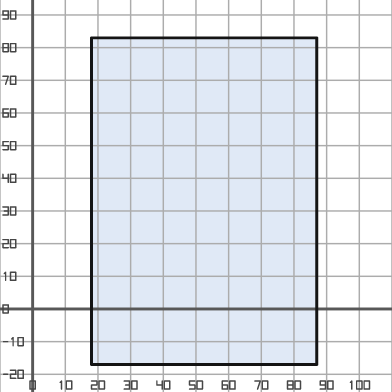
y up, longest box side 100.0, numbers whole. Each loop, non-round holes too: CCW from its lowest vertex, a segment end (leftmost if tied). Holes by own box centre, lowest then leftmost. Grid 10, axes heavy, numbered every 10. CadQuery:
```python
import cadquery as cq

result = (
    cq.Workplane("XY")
    .moveTo(18.0, -17.0)
    .lineTo(87.0, -17.0)
    .lineTo(87.0, 83.0)
    .lineTo(18.0, 83.0)
    .close()
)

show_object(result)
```